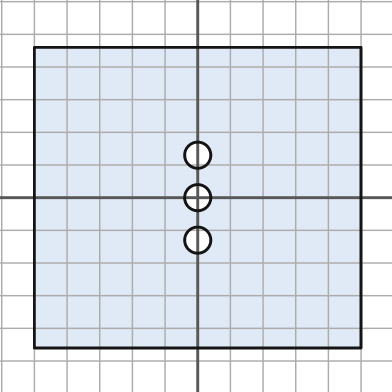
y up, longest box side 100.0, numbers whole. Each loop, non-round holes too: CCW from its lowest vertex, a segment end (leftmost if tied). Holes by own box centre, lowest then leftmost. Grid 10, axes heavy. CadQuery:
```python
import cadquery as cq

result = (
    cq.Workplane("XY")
    .moveTo(-50.0, -46.0)
    .lineTo(50.0, -46.0)
    .lineTo(50.0, 46.0)
    .lineTo(-50.0, 46.0)
    .close()
    .moveTo(0.0, -13.0)
    .circle(4.0)
    .moveTo(0.0, 0.0)
    .circle(4.0)
    .moveTo(0.0, 13.0)
    .circle(4.0)
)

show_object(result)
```